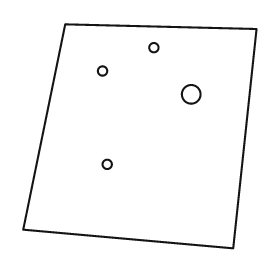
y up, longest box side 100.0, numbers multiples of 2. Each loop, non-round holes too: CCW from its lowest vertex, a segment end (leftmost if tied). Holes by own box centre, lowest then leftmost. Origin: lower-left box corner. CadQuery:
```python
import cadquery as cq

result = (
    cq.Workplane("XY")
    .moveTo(90.0, 0.0)
    .lineTo(100.0, 94.0)
    .lineTo(18.0, 96.0)
    .lineTo(0.0, 8.0)
    .close()
    .moveTo(36.0, 36.0)
    .circle(2.0)
    .moveTo(72.0, 66.0)
    .circle(4.0)
    .moveTo(34.0, 76.0)
    .circle(2.0)
    .moveTo(56.0, 86.0)
    .circle(2.0)
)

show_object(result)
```